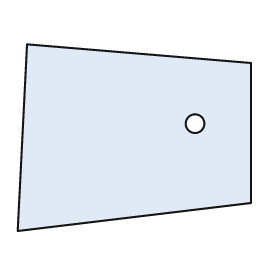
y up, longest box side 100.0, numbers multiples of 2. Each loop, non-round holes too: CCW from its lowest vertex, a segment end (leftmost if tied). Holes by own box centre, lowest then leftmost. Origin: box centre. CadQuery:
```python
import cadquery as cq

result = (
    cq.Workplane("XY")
    .moveTo(-50.0, -40.0)
    .lineTo(50.0, -28.0)
    .lineTo(50.0, 32.0)
    .lineTo(-46.0, 40.0)
    .close()
    .moveTo(26.0, 6.0)
    .circle(4.0)
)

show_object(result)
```